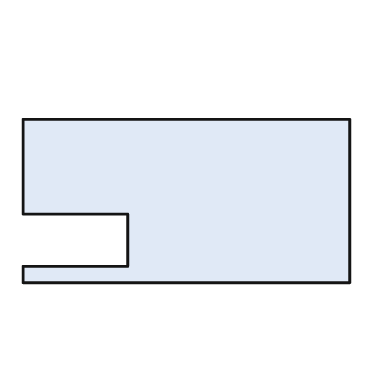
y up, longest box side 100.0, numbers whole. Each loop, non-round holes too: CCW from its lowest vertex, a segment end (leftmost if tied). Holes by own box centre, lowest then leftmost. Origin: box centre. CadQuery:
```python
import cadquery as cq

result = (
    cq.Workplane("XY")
    .moveTo(-50.0, -25.0)
    .lineTo(50.0, -25.0)
    .lineTo(50.0, 25.0)
    .lineTo(-50.0, 25.0)
    .lineTo(-50.0, -4.0)
    .lineTo(-18.0, -4.0)
    .lineTo(-18.0, -20.0)
    .lineTo(-50.0, -20.0)
    .close()
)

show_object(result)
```